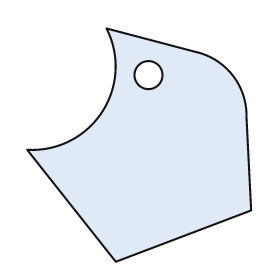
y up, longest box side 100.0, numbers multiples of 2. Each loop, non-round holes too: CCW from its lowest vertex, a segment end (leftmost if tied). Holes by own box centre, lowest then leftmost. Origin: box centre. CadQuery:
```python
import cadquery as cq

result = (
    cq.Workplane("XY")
    .moveTo(-10.0, -50.0)
    .lineTo(48.0, -28.0)
    .lineTo(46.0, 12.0)
    .threePointArc((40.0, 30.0), (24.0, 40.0))
    .lineTo(-14.0, 50.0)
    .threePointArc((-16.0, 14.0), (-48.0, -2.0))
    .close()
    .moveTo(4.0, 30.0)
    .circle(6.0)
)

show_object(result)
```